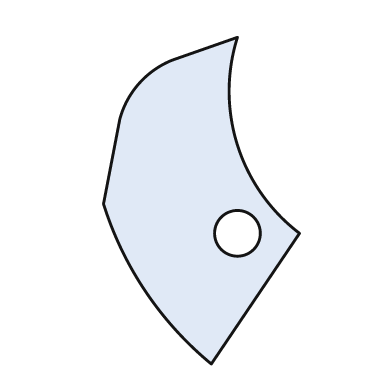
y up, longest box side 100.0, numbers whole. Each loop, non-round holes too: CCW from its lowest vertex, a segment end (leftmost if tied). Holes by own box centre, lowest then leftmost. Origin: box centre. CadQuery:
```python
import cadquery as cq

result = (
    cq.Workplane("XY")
    .moveTo(3.0, -50.0)
    .lineTo(30.0, -10.0)
    .threePointArc((11.0, 17.0), (11.0, 50.0))
    .lineTo(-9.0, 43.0)
    .threePointArc((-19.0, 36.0), (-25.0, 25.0))
    .lineTo(-30.0, -1.0)
    .threePointArc((-17.0, -28.0), (3.0, -50.0))
    .close()
    .moveTo(11.0, -10.0)
    .circle(7.0)
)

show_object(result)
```